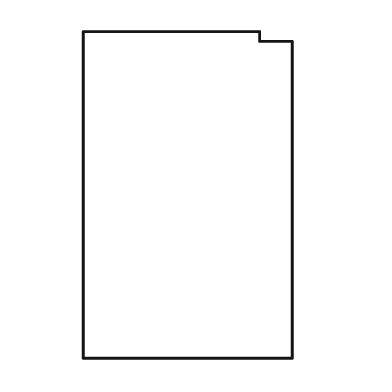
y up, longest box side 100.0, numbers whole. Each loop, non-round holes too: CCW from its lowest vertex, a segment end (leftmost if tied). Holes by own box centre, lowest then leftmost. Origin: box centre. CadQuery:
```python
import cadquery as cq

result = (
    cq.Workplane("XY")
    .moveTo(-32.0, -50.0)
    .lineTo(32.0, -50.0)
    .lineTo(32.0, 47.0)
    .lineTo(22.0, 47.0)
    .lineTo(22.0, 50.0)
    .lineTo(-32.0, 50.0)
    .close()
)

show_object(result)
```